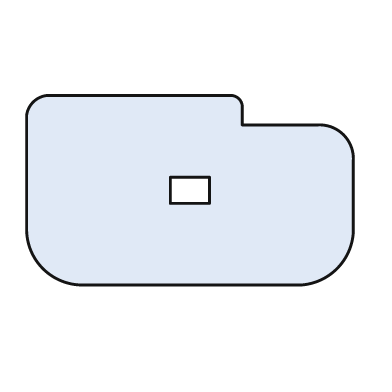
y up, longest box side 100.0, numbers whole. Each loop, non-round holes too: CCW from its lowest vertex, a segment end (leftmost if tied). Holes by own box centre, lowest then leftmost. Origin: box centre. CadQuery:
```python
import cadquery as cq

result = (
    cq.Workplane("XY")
    .moveTo(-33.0, -29.0)
    .lineTo(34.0, -29.0)
    .threePointArc((45.0, -24.0), (50.0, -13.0))
    .lineTo(50.0, 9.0)
    .threePointArc((47.0, 17.0), (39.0, 20.0))
    .lineTo(16.0, 20.0)
    .lineTo(16.0, 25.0)
    .threePointArc((15.0, 28.0), (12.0, 29.0))
    .lineTo(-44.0, 29.0)
    .threePointArc((-48.0, 27.0), (-50.0, 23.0))
    .lineTo(-50.0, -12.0)
    .threePointArc((-45.0, -24.0), (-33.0, -29.0))
    .close()
    .moveTo(-6.0, -4.0)
    .lineTo(6.0, -4.0)
    .lineTo(6.0, 4.0)
    .lineTo(-6.0, 4.0)
    .close()
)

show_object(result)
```